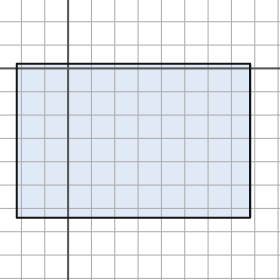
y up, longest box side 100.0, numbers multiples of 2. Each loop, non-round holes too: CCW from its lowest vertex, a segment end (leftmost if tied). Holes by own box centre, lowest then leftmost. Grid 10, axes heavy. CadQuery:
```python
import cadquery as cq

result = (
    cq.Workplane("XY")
    .moveTo(-22.0, -64.0)
    .lineTo(78.0, -64.0)
    .lineTo(78.0, 2.0)
    .lineTo(-22.0, 2.0)
    .close()
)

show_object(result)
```